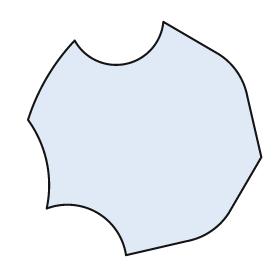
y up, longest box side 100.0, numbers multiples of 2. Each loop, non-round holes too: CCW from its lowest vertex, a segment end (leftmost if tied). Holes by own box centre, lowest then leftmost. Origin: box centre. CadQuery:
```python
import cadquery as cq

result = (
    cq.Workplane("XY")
    .moveTo(-8.0, -50.0)
    .lineTo(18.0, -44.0)
    .threePointArc((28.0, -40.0), (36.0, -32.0))
    .lineTo(50.0, -8.0)
    .lineTo(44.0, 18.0)
    .threePointArc((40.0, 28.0), (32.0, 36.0))
    .lineTo(8.0, 50.0)
    .threePointArc((-8.0, 32.0), (-30.0, 42.0))
    .threePointArc((-42.0, 26.0), (-50.0, 8.0))
    .threePointArc((-42.0, -10.0), (-42.0, -30.0))
    .threePointArc((-20.0, -32.0), (-8.0, -50.0))
    .close()
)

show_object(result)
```